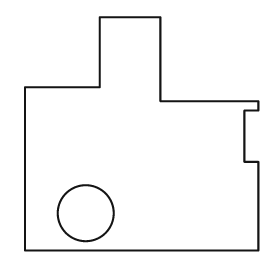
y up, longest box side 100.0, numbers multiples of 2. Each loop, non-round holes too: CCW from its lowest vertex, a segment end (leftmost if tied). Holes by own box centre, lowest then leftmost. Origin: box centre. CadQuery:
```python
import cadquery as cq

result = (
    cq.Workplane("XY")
    .moveTo(-50.0, -50.0)
    .lineTo(50.0, -50.0)
    .lineTo(50.0, -12.0)
    .lineTo(44.0, -12.0)
    .lineTo(44.0, 10.0)
    .lineTo(50.0, 10.0)
    .lineTo(50.0, 14.0)
    .lineTo(8.0, 14.0)
    .lineTo(8.0, 50.0)
    .lineTo(-18.0, 50.0)
    .lineTo(-18.0, 20.0)
    .lineTo(-50.0, 20.0)
    .close()
    .moveTo(-24.0, -34.0)
    .circle(12.0)
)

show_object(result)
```